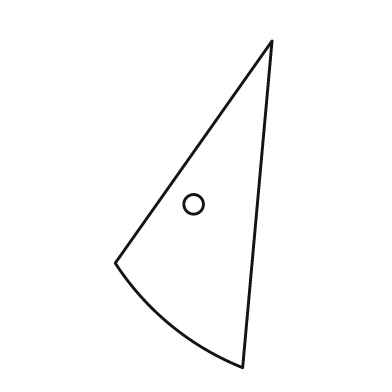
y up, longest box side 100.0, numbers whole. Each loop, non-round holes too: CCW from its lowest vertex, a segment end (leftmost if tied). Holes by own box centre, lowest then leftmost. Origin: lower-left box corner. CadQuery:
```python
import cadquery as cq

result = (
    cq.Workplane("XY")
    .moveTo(39.0, 0.0)
    .lineTo(48.0, 100.0)
    .lineTo(0.0, 32.0)
    .threePointArc((17.0, 13.0), (39.0, 0.0))
    .close()
    .moveTo(24.0, 50.0)
    .circle(3.0)
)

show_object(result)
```